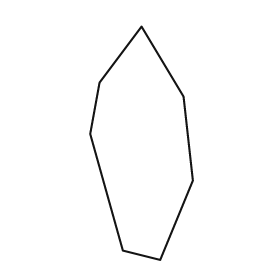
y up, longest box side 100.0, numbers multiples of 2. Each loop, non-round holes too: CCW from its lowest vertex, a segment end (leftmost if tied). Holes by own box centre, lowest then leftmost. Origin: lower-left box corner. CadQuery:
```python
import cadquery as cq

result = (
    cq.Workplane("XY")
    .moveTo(30.0, 0.0)
    .lineTo(44.0, 34.0)
    .lineTo(40.0, 70.0)
    .lineTo(22.0, 100.0)
    .lineTo(4.0, 76.0)
    .lineTo(0.0, 54.0)
    .lineTo(14.0, 4.0)
    .close()
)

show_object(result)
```